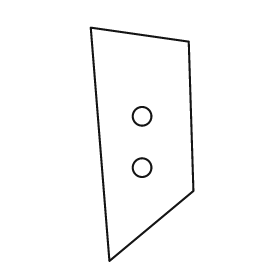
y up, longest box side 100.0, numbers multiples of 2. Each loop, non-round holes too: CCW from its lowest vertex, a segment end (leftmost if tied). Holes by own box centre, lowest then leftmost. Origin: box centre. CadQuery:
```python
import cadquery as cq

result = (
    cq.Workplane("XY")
    .moveTo(-14.0, -50.0)
    .lineTo(22.0, -20.0)
    .lineTo(20.0, 44.0)
    .lineTo(-22.0, 50.0)
    .close()
    .moveTo(0.0, -10.0)
    .circle(4.0)
    .moveTo(0.0, 12.0)
    .circle(4.0)
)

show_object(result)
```